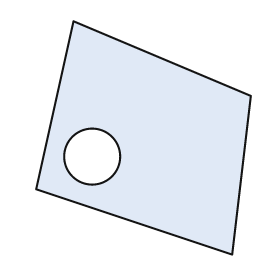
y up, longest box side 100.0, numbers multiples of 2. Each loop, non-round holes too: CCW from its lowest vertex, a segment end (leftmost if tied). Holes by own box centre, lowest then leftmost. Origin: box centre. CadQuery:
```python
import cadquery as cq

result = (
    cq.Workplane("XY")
    .moveTo(38.0, -50.0)
    .lineTo(46.0, 18.0)
    .lineTo(-30.0, 50.0)
    .lineTo(-46.0, -22.0)
    .close()
    .moveTo(-22.0, -8.0)
    .circle(12.0)
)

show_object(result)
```